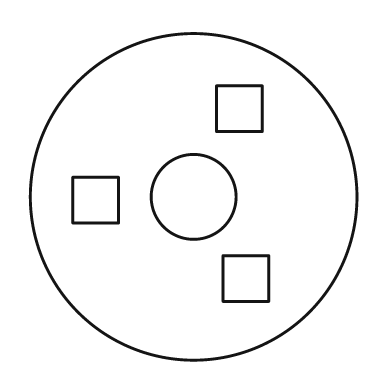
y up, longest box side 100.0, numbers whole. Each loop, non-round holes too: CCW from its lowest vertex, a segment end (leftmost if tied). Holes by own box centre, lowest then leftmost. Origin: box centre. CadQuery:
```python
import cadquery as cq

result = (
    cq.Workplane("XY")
    .moveTo(0.0, 0.0)
    .circle(50.0)
    .moveTo(9.0, -32.0)
    .lineTo(23.0, -32.0)
    .lineTo(23.0, -18.0)
    .lineTo(9.0, -18.0)
    .close()
    .moveTo(-37.0, -8.0)
    .lineTo(-23.0, -8.0)
    .lineTo(-23.0, 6.0)
    .lineTo(-37.0, 6.0)
    .close()
    .moveTo(0.0, 0.0)
    .circle(13.0)
    .moveTo(7.0, 20.0)
    .lineTo(21.0, 20.0)
    .lineTo(21.0, 34.0)
    .lineTo(7.0, 34.0)
    .close()
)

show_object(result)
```